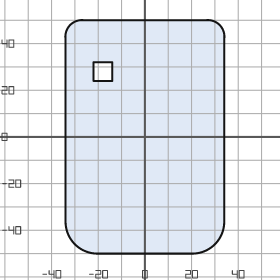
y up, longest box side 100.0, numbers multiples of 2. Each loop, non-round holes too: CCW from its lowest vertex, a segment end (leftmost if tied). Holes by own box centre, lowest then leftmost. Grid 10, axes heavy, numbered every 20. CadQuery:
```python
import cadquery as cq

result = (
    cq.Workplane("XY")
    .moveTo(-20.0, -50.0)
    .lineTo(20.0, -50.0)
    .threePointArc((30.0, -46.0), (34.0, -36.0))
    .lineTo(34.0, 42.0)
    .threePointArc((32.0, 48.0), (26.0, 50.0))
    .lineTo(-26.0, 50.0)
    .threePointArc((-32.0, 48.0), (-34.0, 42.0))
    .lineTo(-34.0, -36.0)
    .threePointArc((-30.0, -46.0), (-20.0, -50.0))
    .close()
    .moveTo(-22.0, 24.0)
    .lineTo(-14.0, 24.0)
    .lineTo(-14.0, 32.0)
    .lineTo(-22.0, 32.0)
    .close()
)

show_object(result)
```